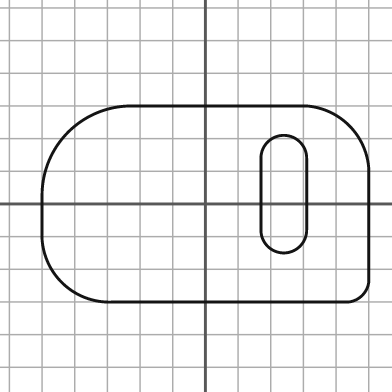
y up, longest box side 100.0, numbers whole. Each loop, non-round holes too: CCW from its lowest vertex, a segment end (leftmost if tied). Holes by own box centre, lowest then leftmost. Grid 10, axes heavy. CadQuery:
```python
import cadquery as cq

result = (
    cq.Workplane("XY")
    .moveTo(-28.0, -30.0)
    .lineTo(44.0, -30.0)
    .threePointArc((48.0, -28.0), (50.0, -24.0))
    .lineTo(50.0, 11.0)
    .threePointArc((44.0, 24.0), (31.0, 30.0))
    .lineTo(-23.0, 30.0)
    .threePointArc((-42.0, 22.0), (-50.0, 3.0))
    .lineTo(-50.0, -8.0)
    .threePointArc((-44.0, -24.0), (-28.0, -30.0))
    .close()
    .moveTo(17.0, -8.0)
    .threePointArc((24.0, -15.0), (31.0, -8.0))
    .lineTo(31.0, 14.0)
    .threePointArc((24.0, 21.0), (17.0, 14.0))
    .close()
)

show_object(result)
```